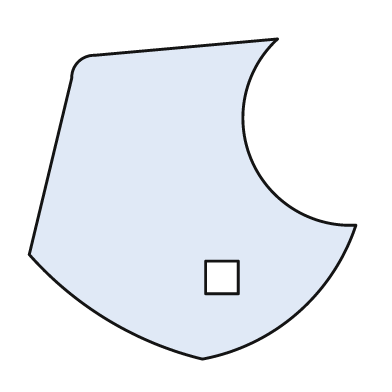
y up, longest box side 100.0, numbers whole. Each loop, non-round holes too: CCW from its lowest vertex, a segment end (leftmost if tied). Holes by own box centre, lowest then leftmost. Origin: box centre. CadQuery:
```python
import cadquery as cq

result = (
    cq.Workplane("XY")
    .moveTo(3.0, -49.0)
    .threePointArc((32.0, -35.0), (50.0, -8.0))
    .threePointArc((18.0, 12.0), (26.0, 49.0))
    .lineTo(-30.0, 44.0)
    .threePointArc((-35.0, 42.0), (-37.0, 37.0))
    .lineTo(-50.0, -17.0)
    .threePointArc((-26.0, -37.0), (3.0, -49.0))
    .close()
    .moveTo(4.0, -29.0)
    .lineTo(14.0, -29.0)
    .lineTo(14.0, -19.0)
    .lineTo(4.0, -19.0)
    .close()
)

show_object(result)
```